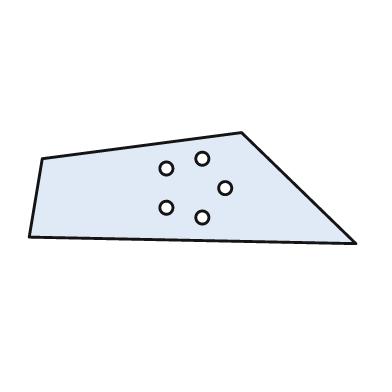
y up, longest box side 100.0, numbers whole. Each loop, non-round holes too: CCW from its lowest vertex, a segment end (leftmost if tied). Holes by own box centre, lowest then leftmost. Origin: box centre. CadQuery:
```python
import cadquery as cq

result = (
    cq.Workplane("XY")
    .moveTo(50.0, -17.0)
    .lineTo(15.0, 17.0)
    .lineTo(-46.0, 9.0)
    .lineTo(-50.0, -15.0)
    .close()
    .moveTo(3.0, -9.0)
    .circle(2.0)
    .moveTo(-8.0, -6.0)
    .circle(2.0)
    .moveTo(10.0, 0.0)
    .circle(2.0)
    .moveTo(-8.0, 6.0)
    .circle(2.0)
    .moveTo(3.0, 9.0)
    .circle(2.0)
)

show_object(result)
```